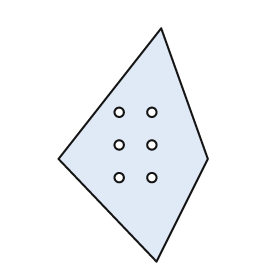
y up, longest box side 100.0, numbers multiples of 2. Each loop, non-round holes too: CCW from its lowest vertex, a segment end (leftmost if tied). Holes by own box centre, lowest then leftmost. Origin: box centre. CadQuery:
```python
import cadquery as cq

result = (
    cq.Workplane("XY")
    .moveTo(10.0, -50.0)
    .lineTo(32.0, -6.0)
    .lineTo(12.0, 50.0)
    .lineTo(-32.0, -6.0)
    .close()
    .moveTo(-6.0, -14.0)
    .circle(2.0)
    .moveTo(8.0, -14.0)
    .circle(2.0)
    .moveTo(-6.0, 0.0)
    .circle(2.0)
    .moveTo(8.0, 0.0)
    .circle(2.0)
    .moveTo(-6.0, 14.0)
    .circle(2.0)
    .moveTo(8.0, 14.0)
    .circle(2.0)
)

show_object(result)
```